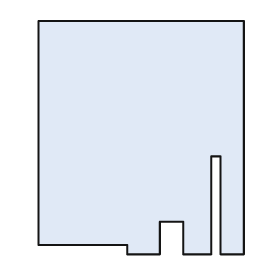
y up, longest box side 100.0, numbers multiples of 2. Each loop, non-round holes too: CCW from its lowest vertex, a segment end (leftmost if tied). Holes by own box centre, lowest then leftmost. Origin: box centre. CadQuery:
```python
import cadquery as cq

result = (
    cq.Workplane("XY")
    .moveTo(-6.0, -50.0)
    .lineTo(8.0, -50.0)
    .lineTo(8.0, -36.0)
    .lineTo(18.0, -36.0)
    .lineTo(18.0, -50.0)
    .lineTo(30.0, -50.0)
    .lineTo(30.0, -8.0)
    .lineTo(34.0, -8.0)
    .lineTo(34.0, -50.0)
    .lineTo(44.0, -50.0)
    .lineTo(44.0, 50.0)
    .lineTo(-44.0, 50.0)
    .lineTo(-44.0, -46.0)
    .lineTo(-6.0, -46.0)
    .close()
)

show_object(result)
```